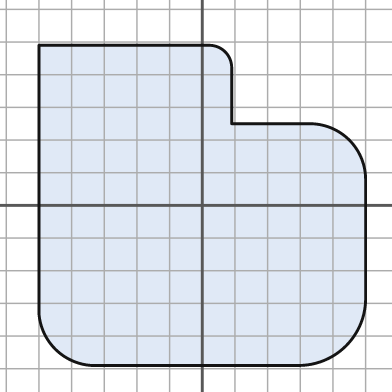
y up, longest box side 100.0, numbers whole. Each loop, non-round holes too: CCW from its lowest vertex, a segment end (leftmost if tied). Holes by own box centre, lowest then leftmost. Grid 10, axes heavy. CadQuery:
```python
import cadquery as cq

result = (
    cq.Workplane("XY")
    .moveTo(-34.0, -49.0)
    .lineTo(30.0, -49.0)
    .threePointArc((44.0, -43.0), (50.0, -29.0))
    .lineTo(50.0, 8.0)
    .threePointArc((45.0, 20.0), (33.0, 25.0))
    .lineTo(9.0, 25.0)
    .lineTo(9.0, 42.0)
    .threePointArc((7.0, 47.0), (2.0, 49.0))
    .lineTo(-50.0, 49.0)
    .lineTo(-50.0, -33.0)
    .threePointArc((-45.0, -44.0), (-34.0, -49.0))
    .close()
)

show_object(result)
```